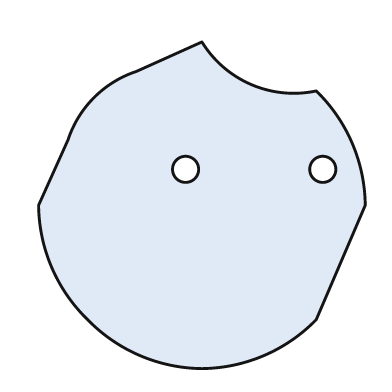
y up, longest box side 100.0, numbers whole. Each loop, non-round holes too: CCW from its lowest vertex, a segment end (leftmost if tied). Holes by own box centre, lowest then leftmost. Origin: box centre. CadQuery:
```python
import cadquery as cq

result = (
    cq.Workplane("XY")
    .moveTo(0.0, -50.0)
    .threePointArc((19.0, -46.0), (35.0, -35.0))
    .lineTo(50.0, 0.0)
    .threePointArc((46.0, 19.0), (35.0, 35.0))
    .threePointArc((15.0, 37.0), (0.0, 50.0))
    .lineTo(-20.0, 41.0)
    .threePointArc((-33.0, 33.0), (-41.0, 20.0))
    .lineTo(-50.0, 0.0)
    .threePointArc((-46.0, -19.0), (-35.0, -35.0))
    .threePointArc((-19.0, -46.0), (0.0, -50.0))
    .close()
    .moveTo(-5.0, 11.0)
    .circle(4.0)
    .moveTo(37.0, 11.0)
    .circle(4.0)
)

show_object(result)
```